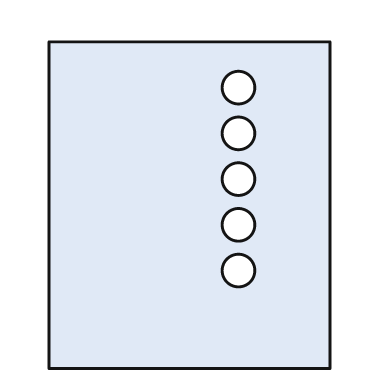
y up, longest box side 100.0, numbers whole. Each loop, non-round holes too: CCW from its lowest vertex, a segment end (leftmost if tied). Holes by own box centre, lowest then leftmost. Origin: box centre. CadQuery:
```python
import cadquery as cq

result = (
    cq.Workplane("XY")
    .moveTo(-43.0, -50.0)
    .lineTo(43.0, -50.0)
    .lineTo(43.0, 50.0)
    .lineTo(-43.0, 50.0)
    .close()
    .moveTo(15.0, -20.0)
    .circle(5.0)
    .moveTo(15.0, -6.0)
    .circle(5.0)
    .moveTo(15.0, 8.0)
    .circle(5.0)
    .moveTo(15.0, 22.0)
    .circle(5.0)
    .moveTo(15.0, 36.0)
    .circle(5.0)
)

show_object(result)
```